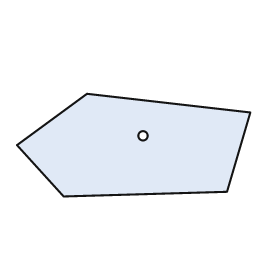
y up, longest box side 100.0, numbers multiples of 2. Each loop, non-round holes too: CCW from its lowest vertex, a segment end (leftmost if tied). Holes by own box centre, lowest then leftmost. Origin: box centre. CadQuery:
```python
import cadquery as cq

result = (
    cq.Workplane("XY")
    .moveTo(-30.0, -22.0)
    .lineTo(40.0, -20.0)
    .lineTo(50.0, 14.0)
    .lineTo(-20.0, 22.0)
    .lineTo(-50.0, 0.0)
    .close()
    .moveTo(4.0, 4.0)
    .circle(2.0)
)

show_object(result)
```